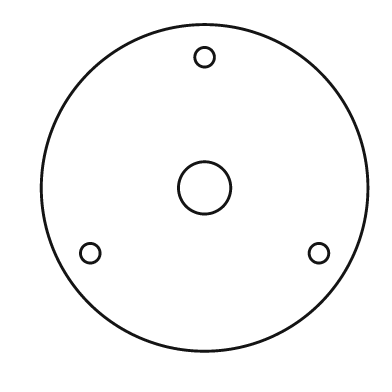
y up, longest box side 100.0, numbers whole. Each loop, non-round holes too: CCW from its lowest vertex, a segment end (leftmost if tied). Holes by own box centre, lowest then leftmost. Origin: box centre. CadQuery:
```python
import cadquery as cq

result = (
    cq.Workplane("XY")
    .moveTo(0.0, 0.0)
    .circle(50.0)
    .moveTo(-35.0, -20.0)
    .circle(3.0)
    .moveTo(35.0, -20.0)
    .circle(3.0)
    .moveTo(0.0, 0.0)
    .circle(8.0)
    .moveTo(0.0, 40.0)
    .circle(3.0)
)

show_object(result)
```